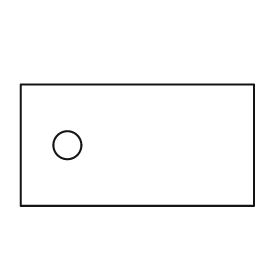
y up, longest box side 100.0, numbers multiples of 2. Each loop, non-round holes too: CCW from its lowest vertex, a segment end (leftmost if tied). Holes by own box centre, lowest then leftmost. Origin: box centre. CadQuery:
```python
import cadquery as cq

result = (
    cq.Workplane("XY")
    .moveTo(-50.0, -26.0)
    .lineTo(50.0, -26.0)
    .lineTo(50.0, 26.0)
    .lineTo(-50.0, 26.0)
    .close()
    .moveTo(-30.0, 0.0)
    .circle(6.0)
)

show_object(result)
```